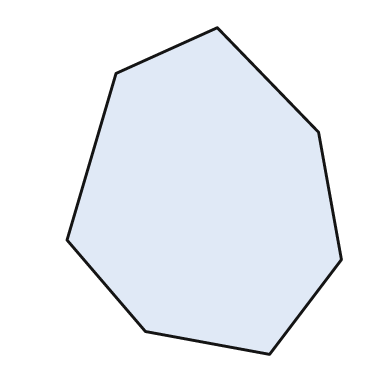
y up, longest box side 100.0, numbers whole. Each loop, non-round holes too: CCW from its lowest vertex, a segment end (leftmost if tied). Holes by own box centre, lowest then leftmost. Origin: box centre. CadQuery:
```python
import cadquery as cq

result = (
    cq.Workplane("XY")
    .moveTo(20.0, -50.0)
    .lineTo(42.0, -21.0)
    .lineTo(35.0, 18.0)
    .lineTo(4.0, 50.0)
    .lineTo(-27.0, 36.0)
    .lineTo(-42.0, -15.0)
    .lineTo(-18.0, -43.0)
    .close()
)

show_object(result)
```